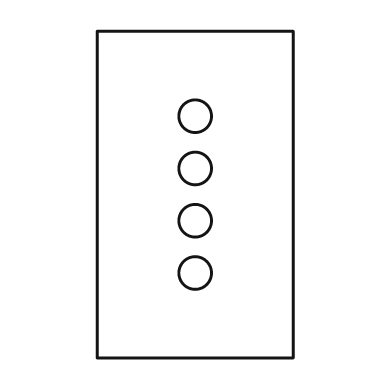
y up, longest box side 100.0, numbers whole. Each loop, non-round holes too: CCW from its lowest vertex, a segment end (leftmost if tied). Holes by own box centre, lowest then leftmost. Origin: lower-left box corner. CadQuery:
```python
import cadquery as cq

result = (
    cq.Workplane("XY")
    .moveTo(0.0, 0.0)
    .lineTo(60.0, 0.0)
    .lineTo(60.0, 100.0)
    .lineTo(0.0, 100.0)
    .close()
    .moveTo(30.0, 26.0)
    .circle(5.0)
    .moveTo(30.0, 42.0)
    .circle(5.0)
    .moveTo(30.0, 58.0)
    .circle(5.0)
    .moveTo(30.0, 74.0)
    .circle(5.0)
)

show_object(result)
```